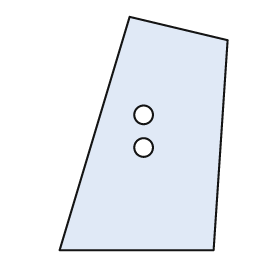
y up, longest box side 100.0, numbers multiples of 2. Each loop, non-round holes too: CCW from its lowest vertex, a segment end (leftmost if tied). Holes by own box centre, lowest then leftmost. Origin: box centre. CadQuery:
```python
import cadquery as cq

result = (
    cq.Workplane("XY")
    .moveTo(-36.0, -50.0)
    .lineTo(30.0, -50.0)
    .lineTo(36.0, 40.0)
    .lineTo(-6.0, 50.0)
    .close()
    .moveTo(0.0, -6.0)
    .circle(4.0)
    .moveTo(0.0, 8.0)
    .circle(4.0)
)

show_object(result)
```